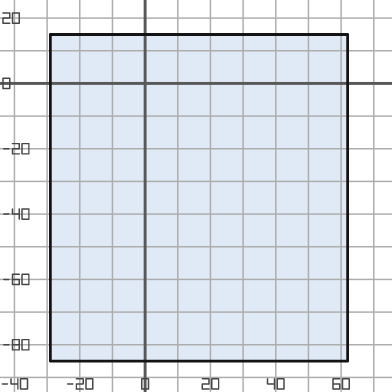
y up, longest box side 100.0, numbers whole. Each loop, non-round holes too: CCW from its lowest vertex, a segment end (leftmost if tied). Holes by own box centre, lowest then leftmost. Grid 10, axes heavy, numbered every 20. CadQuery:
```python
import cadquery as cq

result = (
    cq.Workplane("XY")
    .moveTo(-29.0, -85.0)
    .lineTo(62.0, -85.0)
    .lineTo(62.0, 15.0)
    .lineTo(-29.0, 15.0)
    .close()
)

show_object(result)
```